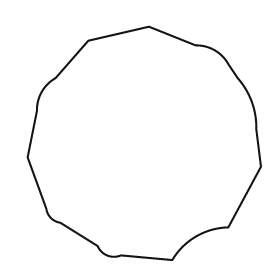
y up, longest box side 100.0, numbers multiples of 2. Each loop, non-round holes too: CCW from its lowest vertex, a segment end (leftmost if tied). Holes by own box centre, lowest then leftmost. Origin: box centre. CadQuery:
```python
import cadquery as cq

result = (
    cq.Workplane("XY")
    .moveTo(12.0, -50.0)
    .threePointArc((22.0, -40.0), (36.0, -36.0))
    .lineTo(50.0, -10.0)
    .lineTo(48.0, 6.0)
    .threePointArc((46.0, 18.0), (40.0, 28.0))
    .lineTo(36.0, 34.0)
    .threePointArc((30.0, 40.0), (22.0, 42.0))
    .lineTo(2.0, 50.0)
    .lineTo(-24.0, 44.0)
    .lineTo(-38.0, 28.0)
    .threePointArc((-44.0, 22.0), (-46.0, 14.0))
    .lineTo(-50.0, -6.0)
    .lineTo(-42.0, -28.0)
    .threePointArc((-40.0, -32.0), (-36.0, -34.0))
    .lineTo(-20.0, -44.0)
    .threePointArc((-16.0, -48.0), (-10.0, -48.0))
    .close()
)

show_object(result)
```